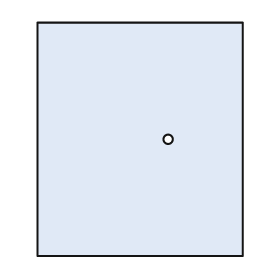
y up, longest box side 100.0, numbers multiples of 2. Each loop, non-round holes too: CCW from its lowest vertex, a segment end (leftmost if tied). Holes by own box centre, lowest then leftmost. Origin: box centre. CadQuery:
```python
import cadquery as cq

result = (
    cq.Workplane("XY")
    .moveTo(-44.0, -50.0)
    .lineTo(44.0, -50.0)
    .lineTo(44.0, 50.0)
    .lineTo(-44.0, 50.0)
    .close()
    .moveTo(12.0, 0.0)
    .circle(2.0)
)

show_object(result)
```